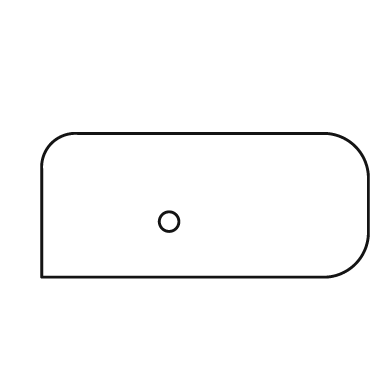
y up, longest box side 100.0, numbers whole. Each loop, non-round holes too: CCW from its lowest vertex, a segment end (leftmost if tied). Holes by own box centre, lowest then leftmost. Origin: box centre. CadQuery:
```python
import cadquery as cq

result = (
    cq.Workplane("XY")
    .moveTo(-50.0, -22.0)
    .lineTo(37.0, -22.0)
    .threePointArc((46.0, -18.0), (50.0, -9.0))
    .lineTo(50.0, 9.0)
    .threePointArc((46.0, 18.0), (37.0, 22.0))
    .lineTo(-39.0, 22.0)
    .threePointArc((-47.0, 19.0), (-50.0, 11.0))
    .close()
    .moveTo(-11.0, -5.0)
    .circle(3.0)
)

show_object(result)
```